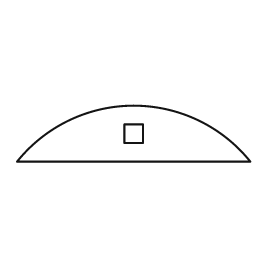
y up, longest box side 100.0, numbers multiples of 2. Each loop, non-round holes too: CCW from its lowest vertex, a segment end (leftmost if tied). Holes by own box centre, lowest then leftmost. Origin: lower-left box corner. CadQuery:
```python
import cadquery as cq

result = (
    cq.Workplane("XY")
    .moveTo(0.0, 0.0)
    .lineTo(100.0, 0.0)
    .threePointArc((50.0, 24.0), (0.0, 0.0))
    .close()
    .moveTo(46.0, 8.0)
    .lineTo(54.0, 8.0)
    .lineTo(54.0, 16.0)
    .lineTo(46.0, 16.0)
    .close()
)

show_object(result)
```